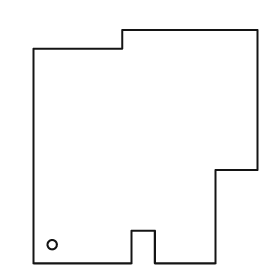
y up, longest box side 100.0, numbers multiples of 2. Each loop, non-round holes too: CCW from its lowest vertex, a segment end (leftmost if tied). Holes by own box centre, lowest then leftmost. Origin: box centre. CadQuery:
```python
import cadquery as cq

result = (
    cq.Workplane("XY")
    .moveTo(-48.0, -50.0)
    .lineTo(-6.0, -50.0)
    .lineTo(-6.0, -36.0)
    .lineTo(4.0, -36.0)
    .lineTo(4.0, -50.0)
    .lineTo(30.0, -50.0)
    .lineTo(30.0, -10.0)
    .lineTo(48.0, -10.0)
    .lineTo(48.0, 50.0)
    .lineTo(-10.0, 50.0)
    .lineTo(-10.0, 42.0)
    .lineTo(-48.0, 42.0)
    .close()
    .moveTo(-40.0, -42.0)
    .circle(2.0)
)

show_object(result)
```